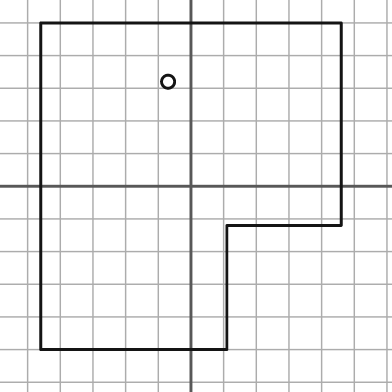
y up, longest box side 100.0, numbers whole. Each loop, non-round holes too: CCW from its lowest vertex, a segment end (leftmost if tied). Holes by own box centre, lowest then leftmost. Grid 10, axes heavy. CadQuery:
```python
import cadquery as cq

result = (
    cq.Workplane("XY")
    .moveTo(-46.0, -50.0)
    .lineTo(11.0, -50.0)
    .lineTo(11.0, -12.0)
    .lineTo(46.0, -12.0)
    .lineTo(46.0, 50.0)
    .lineTo(-46.0, 50.0)
    .close()
    .moveTo(-7.0, 32.0)
    .circle(2.0)
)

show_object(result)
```